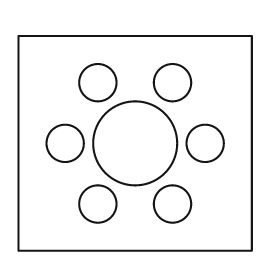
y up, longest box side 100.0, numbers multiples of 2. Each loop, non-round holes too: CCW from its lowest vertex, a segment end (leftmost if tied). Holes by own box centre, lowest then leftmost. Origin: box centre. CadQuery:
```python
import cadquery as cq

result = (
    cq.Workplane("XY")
    .moveTo(-50.0, -46.0)
    .lineTo(50.0, -46.0)
    .lineTo(50.0, 46.0)
    .lineTo(-50.0, 46.0)
    .close()
    .moveTo(-16.0, -26.0)
    .circle(8.0)
    .moveTo(16.0, -26.0)
    .circle(8.0)
    .moveTo(-30.0, 0.0)
    .circle(8.0)
    .moveTo(0.0, 0.0)
    .circle(18.0)
    .moveTo(30.0, 0.0)
    .circle(8.0)
    .moveTo(-16.0, 26.0)
    .circle(8.0)
    .moveTo(16.0, 26.0)
    .circle(8.0)
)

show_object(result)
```